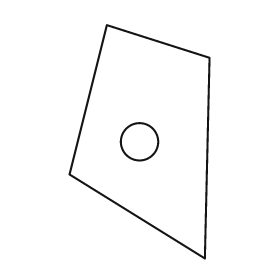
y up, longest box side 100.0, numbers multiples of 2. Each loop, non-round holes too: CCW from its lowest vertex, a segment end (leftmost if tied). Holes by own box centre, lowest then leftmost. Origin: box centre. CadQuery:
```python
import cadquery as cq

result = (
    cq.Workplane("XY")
    .moveTo(28.0, -50.0)
    .lineTo(30.0, 36.0)
    .lineTo(-14.0, 50.0)
    .lineTo(-30.0, -14.0)
    .close()
    .moveTo(0.0, 0.0)
    .circle(8.0)
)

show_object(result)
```